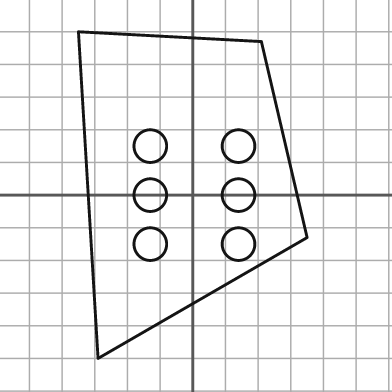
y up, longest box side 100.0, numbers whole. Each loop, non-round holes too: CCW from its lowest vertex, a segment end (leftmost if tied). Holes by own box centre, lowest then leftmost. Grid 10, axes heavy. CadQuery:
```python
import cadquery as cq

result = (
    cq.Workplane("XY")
    .moveTo(-29.0, -50.0)
    .lineTo(35.0, -13.0)
    .lineTo(21.0, 47.0)
    .lineTo(-35.0, 50.0)
    .close()
    .moveTo(-13.0, -15.0)
    .circle(5.0)
    .moveTo(14.0, -15.0)
    .circle(5.0)
    .moveTo(-13.0, 0.0)
    .circle(5.0)
    .moveTo(14.0, 0.0)
    .circle(5.0)
    .moveTo(-13.0, 15.0)
    .circle(5.0)
    .moveTo(14.0, 15.0)
    .circle(5.0)
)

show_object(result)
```